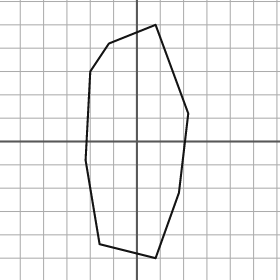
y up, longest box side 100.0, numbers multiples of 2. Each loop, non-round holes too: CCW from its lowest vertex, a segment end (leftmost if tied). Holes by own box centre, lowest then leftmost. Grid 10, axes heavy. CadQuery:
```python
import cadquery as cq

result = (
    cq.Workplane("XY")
    .moveTo(8.0, -50.0)
    .lineTo(18.0, -22.0)
    .lineTo(22.0, 12.0)
    .lineTo(8.0, 50.0)
    .lineTo(-12.0, 42.0)
    .lineTo(-20.0, 30.0)
    .lineTo(-22.0, -8.0)
    .lineTo(-16.0, -44.0)
    .close()
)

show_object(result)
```